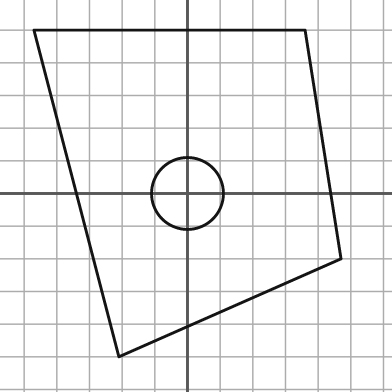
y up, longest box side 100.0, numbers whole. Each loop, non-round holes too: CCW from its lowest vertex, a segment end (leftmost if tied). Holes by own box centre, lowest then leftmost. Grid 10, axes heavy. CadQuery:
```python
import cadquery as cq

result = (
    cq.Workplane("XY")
    .moveTo(-21.0, -50.0)
    .lineTo(47.0, -20.0)
    .lineTo(36.0, 50.0)
    .lineTo(-47.0, 50.0)
    .close()
    .moveTo(0.0, 0.0)
    .circle(11.0)
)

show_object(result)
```